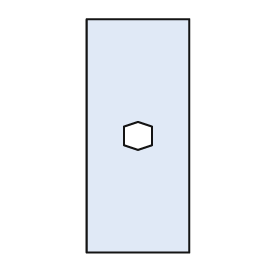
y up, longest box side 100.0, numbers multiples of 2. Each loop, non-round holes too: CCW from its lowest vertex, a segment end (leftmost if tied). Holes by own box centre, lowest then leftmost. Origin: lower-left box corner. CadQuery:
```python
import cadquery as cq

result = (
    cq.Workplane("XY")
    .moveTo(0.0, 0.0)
    .lineTo(44.0, 0.0)
    .lineTo(44.0, 100.0)
    .lineTo(0.0, 100.0)
    .close()
    .moveTo(22.0, 44.0)
    .lineTo(28.0, 46.0)
    .lineTo(28.0, 54.0)
    .lineTo(22.0, 56.0)
    .lineTo(16.0, 54.0)
    .lineTo(16.0, 46.0)
    .close()
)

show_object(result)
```